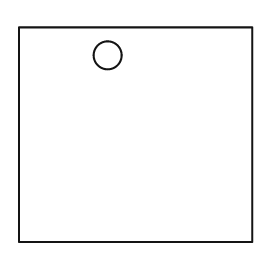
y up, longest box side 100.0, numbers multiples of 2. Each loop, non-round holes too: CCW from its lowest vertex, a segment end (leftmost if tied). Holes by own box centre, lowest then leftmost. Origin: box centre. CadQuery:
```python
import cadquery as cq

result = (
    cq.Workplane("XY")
    .moveTo(-50.0, -46.0)
    .lineTo(50.0, -46.0)
    .lineTo(50.0, 46.0)
    .lineTo(-50.0, 46.0)
    .close()
    .moveTo(-12.0, 34.0)
    .circle(6.0)
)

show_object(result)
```